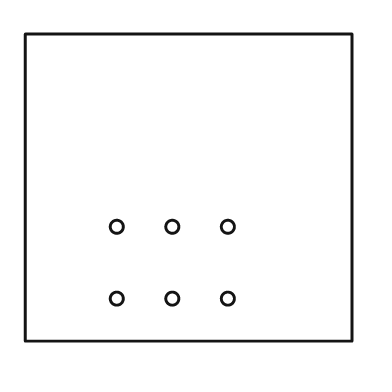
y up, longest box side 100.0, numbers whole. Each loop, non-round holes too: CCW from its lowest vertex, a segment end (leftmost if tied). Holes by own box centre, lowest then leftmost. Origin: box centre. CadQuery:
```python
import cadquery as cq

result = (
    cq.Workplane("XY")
    .moveTo(-50.0, -47.0)
    .lineTo(50.0, -47.0)
    .lineTo(50.0, 47.0)
    .lineTo(-50.0, 47.0)
    .close()
    .moveTo(-22.0, -34.0)
    .circle(2.0)
    .moveTo(-5.0, -34.0)
    .circle(2.0)
    .moveTo(12.0, -34.0)
    .circle(2.0)
    .moveTo(-22.0, -12.0)
    .circle(2.0)
    .moveTo(-5.0, -12.0)
    .circle(2.0)
    .moveTo(12.0, -12.0)
    .circle(2.0)
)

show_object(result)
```